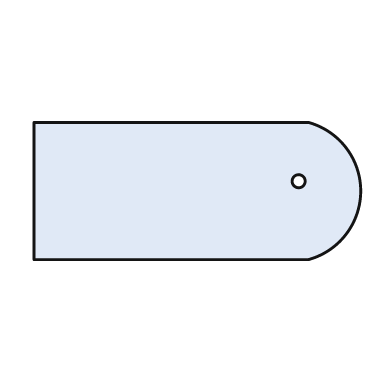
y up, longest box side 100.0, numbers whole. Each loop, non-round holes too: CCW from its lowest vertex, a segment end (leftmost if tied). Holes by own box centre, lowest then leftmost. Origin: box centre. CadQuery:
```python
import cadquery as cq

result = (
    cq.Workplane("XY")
    .moveTo(-50.0, -21.0)
    .lineTo(34.0, -21.0)
    .threePointArc((50.0, 0.0), (34.0, 21.0))
    .lineTo(-50.0, 21.0)
    .close()
    .moveTo(31.0, 3.0)
    .circle(2.0)
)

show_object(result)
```